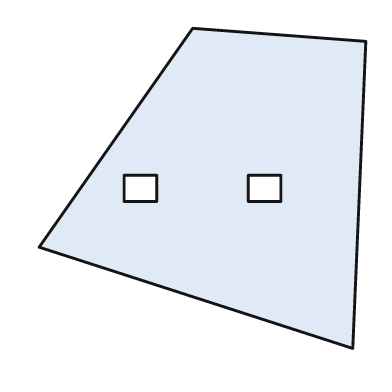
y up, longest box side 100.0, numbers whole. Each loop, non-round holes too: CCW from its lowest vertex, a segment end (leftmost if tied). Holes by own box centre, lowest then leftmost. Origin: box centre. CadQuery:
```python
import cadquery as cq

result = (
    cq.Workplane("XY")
    .moveTo(46.0, -49.0)
    .lineTo(50.0, 45.0)
    .lineTo(-3.0, 49.0)
    .lineTo(-50.0, -18.0)
    .close()
    .moveTo(-24.0, -4.0)
    .lineTo(-14.0, -4.0)
    .lineTo(-14.0, 4.0)
    .lineTo(-24.0, 4.0)
    .close()
    .moveTo(14.0, -4.0)
    .lineTo(24.0, -4.0)
    .lineTo(24.0, 4.0)
    .lineTo(14.0, 4.0)
    .close()
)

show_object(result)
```